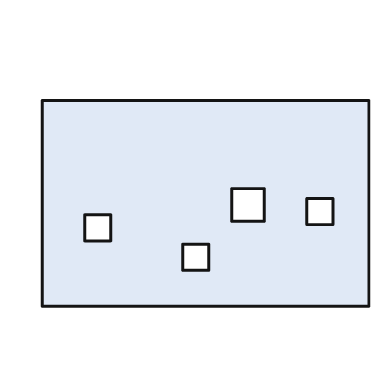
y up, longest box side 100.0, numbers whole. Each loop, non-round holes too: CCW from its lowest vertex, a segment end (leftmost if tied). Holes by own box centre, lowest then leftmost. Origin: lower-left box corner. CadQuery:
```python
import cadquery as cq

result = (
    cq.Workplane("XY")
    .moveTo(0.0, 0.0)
    .lineTo(100.0, 0.0)
    .lineTo(100.0, 63.0)
    .lineTo(0.0, 63.0)
    .close()
    .moveTo(43.0, 11.0)
    .lineTo(51.0, 11.0)
    .lineTo(51.0, 19.0)
    .lineTo(43.0, 19.0)
    .close()
    .moveTo(13.0, 20.0)
    .lineTo(21.0, 20.0)
    .lineTo(21.0, 28.0)
    .lineTo(13.0, 28.0)
    .close()
    .moveTo(81.0, 25.0)
    .lineTo(89.0, 25.0)
    .lineTo(89.0, 33.0)
    .lineTo(81.0, 33.0)
    .close()
    .moveTo(58.0, 26.0)
    .lineTo(68.0, 26.0)
    .lineTo(68.0, 36.0)
    .lineTo(58.0, 36.0)
    .close()
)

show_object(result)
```